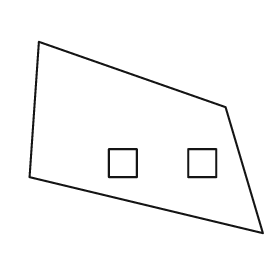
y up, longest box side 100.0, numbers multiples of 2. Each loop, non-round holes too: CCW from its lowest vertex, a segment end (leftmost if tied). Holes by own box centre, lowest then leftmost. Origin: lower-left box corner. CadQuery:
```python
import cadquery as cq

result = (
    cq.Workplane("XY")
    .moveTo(100.0, 0.0)
    .lineTo(84.0, 54.0)
    .lineTo(4.0, 82.0)
    .lineTo(0.0, 24.0)
    .close()
    .moveTo(34.0, 24.0)
    .lineTo(46.0, 24.0)
    .lineTo(46.0, 36.0)
    .lineTo(34.0, 36.0)
    .close()
    .moveTo(68.0, 24.0)
    .lineTo(80.0, 24.0)
    .lineTo(80.0, 36.0)
    .lineTo(68.0, 36.0)
    .close()
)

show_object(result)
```